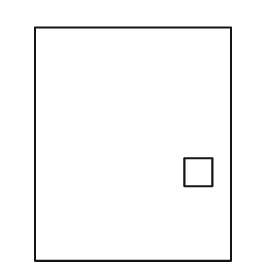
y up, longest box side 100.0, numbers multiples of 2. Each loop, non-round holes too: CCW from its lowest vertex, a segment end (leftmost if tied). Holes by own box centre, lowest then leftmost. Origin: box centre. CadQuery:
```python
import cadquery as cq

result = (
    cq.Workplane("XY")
    .moveTo(-42.0, -50.0)
    .lineTo(42.0, -50.0)
    .lineTo(42.0, 50.0)
    .lineTo(-42.0, 50.0)
    .close()
    .moveTo(22.0, -18.0)
    .lineTo(34.0, -18.0)
    .lineTo(34.0, -6.0)
    .lineTo(22.0, -6.0)
    .close()
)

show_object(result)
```